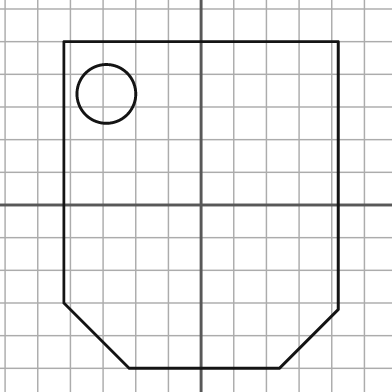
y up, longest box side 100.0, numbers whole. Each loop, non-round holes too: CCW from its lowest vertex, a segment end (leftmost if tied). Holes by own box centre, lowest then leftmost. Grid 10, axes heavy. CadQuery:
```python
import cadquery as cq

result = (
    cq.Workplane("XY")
    .moveTo(-22.0, -50.0)
    .lineTo(24.0, -50.0)
    .lineTo(42.0, -32.0)
    .lineTo(42.0, 50.0)
    .lineTo(-42.0, 50.0)
    .lineTo(-42.0, -30.0)
    .close()
    .moveTo(-29.0, 34.0)
    .circle(9.0)
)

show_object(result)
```